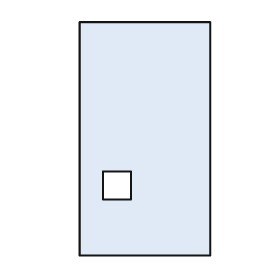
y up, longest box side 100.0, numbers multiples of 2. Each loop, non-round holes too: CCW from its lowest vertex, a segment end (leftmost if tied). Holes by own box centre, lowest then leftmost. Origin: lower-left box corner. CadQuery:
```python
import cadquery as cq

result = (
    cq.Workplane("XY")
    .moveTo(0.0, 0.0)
    .lineTo(56.0, 0.0)
    .lineTo(56.0, 100.0)
    .lineTo(0.0, 100.0)
    .close()
    .moveTo(10.0, 24.0)
    .lineTo(22.0, 24.0)
    .lineTo(22.0, 36.0)
    .lineTo(10.0, 36.0)
    .close()
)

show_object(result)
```